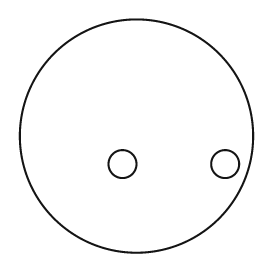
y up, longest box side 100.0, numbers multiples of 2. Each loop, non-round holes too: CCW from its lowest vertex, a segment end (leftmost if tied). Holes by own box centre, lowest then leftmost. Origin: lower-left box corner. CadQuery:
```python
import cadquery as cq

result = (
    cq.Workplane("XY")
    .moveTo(50.0, 50.0)
    .circle(50.0)
    .moveTo(44.0, 38.0)
    .circle(6.0)
    .moveTo(88.0, 38.0)
    .circle(6.0)
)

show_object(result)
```